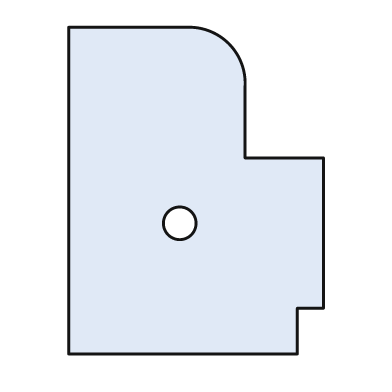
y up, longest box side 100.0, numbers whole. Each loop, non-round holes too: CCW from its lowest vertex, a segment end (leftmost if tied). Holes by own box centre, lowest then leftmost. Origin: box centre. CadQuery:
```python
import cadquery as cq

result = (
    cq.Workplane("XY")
    .moveTo(-39.0, -50.0)
    .lineTo(31.0, -50.0)
    .lineTo(31.0, -36.0)
    .lineTo(39.0, -36.0)
    .lineTo(39.0, 10.0)
    .lineTo(15.0, 10.0)
    .lineTo(15.0, 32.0)
    .threePointArc((10.0, 45.0), (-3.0, 50.0))
    .lineTo(-39.0, 50.0)
    .close()
    .moveTo(-5.0, -10.0)
    .circle(5.0)
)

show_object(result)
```